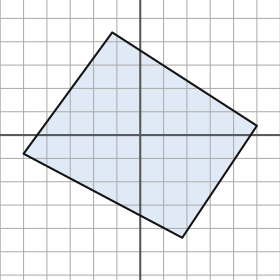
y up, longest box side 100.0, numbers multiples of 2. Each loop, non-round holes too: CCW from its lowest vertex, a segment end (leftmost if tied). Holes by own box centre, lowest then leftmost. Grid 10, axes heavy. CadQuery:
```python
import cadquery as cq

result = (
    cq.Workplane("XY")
    .moveTo(18.0, -44.0)
    .lineTo(50.0, 4.0)
    .lineTo(-12.0, 44.0)
    .lineTo(-50.0, -8.0)
    .close()
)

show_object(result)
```